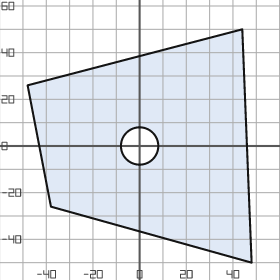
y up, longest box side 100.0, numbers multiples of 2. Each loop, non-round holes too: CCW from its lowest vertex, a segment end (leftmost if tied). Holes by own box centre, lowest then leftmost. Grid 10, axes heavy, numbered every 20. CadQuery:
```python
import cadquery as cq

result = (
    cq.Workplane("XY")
    .moveTo(48.0, -50.0)
    .lineTo(44.0, 50.0)
    .lineTo(-48.0, 26.0)
    .lineTo(-38.0, -26.0)
    .close()
    .moveTo(0.0, 0.0)
    .circle(8.0)
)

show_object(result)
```